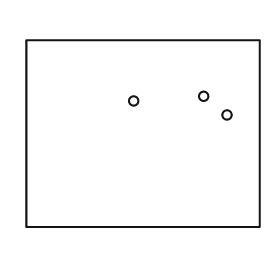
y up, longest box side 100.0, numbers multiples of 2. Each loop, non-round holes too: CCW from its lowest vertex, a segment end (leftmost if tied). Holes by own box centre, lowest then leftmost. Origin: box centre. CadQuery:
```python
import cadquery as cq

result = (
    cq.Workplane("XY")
    .moveTo(-50.0, -40.0)
    .lineTo(50.0, -40.0)
    .lineTo(50.0, 40.0)
    .lineTo(-50.0, 40.0)
    .close()
    .moveTo(36.0, 8.0)
    .circle(2.0)
    .moveTo(-4.0, 14.0)
    .circle(2.0)
    .moveTo(26.0, 16.0)
    .circle(2.0)
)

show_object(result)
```